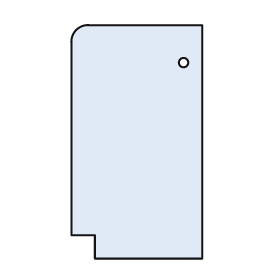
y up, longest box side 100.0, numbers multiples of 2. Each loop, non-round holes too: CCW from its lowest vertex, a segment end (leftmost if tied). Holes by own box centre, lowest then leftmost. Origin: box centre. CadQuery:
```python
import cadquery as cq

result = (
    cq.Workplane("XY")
    .moveTo(-18.0, -50.0)
    .lineTo(28.0, -50.0)
    .lineTo(28.0, 50.0)
    .lineTo(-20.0, 50.0)
    .threePointArc((-26.0, 48.0), (-28.0, 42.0))
    .lineTo(-28.0, -40.0)
    .lineTo(-18.0, -40.0)
    .close()
    .moveTo(20.0, 34.0)
    .circle(2.0)
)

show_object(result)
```